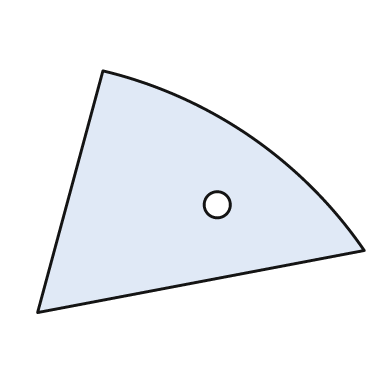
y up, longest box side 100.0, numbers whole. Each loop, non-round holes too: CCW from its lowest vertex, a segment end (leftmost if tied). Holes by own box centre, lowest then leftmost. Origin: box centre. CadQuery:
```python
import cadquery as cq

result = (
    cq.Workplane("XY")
    .moveTo(-50.0, -37.0)
    .lineTo(50.0, -18.0)
    .threePointArc((15.0, 17.0), (-30.0, 37.0))
    .close()
    .moveTo(5.0, -4.0)
    .circle(4.0)
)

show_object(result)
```